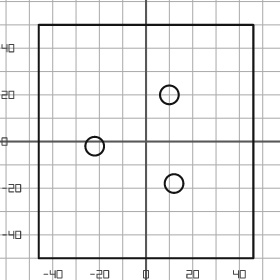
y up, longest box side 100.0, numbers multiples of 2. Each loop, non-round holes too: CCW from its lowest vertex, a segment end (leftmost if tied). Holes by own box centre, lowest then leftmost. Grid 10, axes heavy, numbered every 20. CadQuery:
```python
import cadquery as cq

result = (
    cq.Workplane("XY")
    .moveTo(-46.0, -50.0)
    .lineTo(46.0, -50.0)
    .lineTo(46.0, 50.0)
    .lineTo(-46.0, 50.0)
    .close()
    .moveTo(12.0, -18.0)
    .circle(4.0)
    .moveTo(-22.0, -2.0)
    .circle(4.0)
    .moveTo(10.0, 20.0)
    .circle(4.0)
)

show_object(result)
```